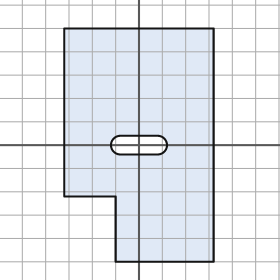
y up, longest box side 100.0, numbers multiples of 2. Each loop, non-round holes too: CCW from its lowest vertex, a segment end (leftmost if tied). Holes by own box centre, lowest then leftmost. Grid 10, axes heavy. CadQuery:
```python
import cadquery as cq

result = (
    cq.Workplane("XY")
    .moveTo(-10.0, -50.0)
    .lineTo(32.0, -50.0)
    .lineTo(32.0, 50.0)
    .lineTo(-32.0, 50.0)
    .lineTo(-32.0, -22.0)
    .lineTo(-10.0, -22.0)
    .close()
    .moveTo(-8.0, -4.0)
    .lineTo(8.0, -4.0)
    .threePointArc((12.0, 0.0), (8.0, 4.0))
    .lineTo(-8.0, 4.0)
    .threePointArc((-12.0, 0.0), (-8.0, -4.0))
    .close()
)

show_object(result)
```